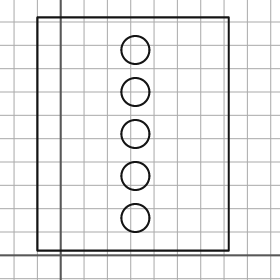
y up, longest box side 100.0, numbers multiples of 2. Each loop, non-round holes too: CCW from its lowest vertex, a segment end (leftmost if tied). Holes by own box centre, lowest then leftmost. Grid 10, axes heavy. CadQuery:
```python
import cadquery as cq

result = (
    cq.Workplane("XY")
    .moveTo(-10.0, 2.0)
    .lineTo(72.0, 2.0)
    .lineTo(72.0, 102.0)
    .lineTo(-10.0, 102.0)
    .close()
    .moveTo(32.0, 16.0)
    .circle(6.0)
    .moveTo(32.0, 34.0)
    .circle(6.0)
    .moveTo(32.0, 52.0)
    .circle(6.0)
    .moveTo(32.0, 70.0)
    .circle(6.0)
    .moveTo(32.0, 88.0)
    .circle(6.0)
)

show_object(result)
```